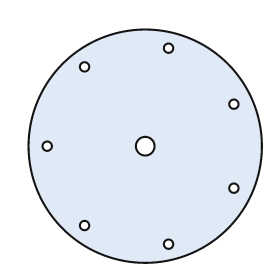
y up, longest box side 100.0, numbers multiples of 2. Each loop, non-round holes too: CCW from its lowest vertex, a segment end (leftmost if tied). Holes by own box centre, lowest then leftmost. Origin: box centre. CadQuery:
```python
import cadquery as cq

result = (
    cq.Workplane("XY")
    .moveTo(0.0, 0.0)
    .circle(50.0)
    .moveTo(10.0, -42.0)
    .circle(2.0)
    .moveTo(-26.0, -34.0)
    .circle(2.0)
    .moveTo(38.0, -18.0)
    .circle(2.0)
    .moveTo(-42.0, 0.0)
    .circle(2.0)
    .moveTo(0.0, 0.0)
    .circle(4.0)
    .moveTo(38.0, 18.0)
    .circle(2.0)
    .moveTo(-26.0, 34.0)
    .circle(2.0)
    .moveTo(10.0, 42.0)
    .circle(2.0)
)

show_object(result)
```